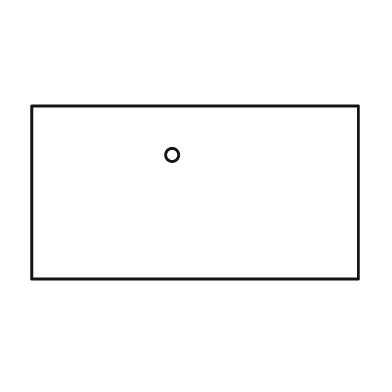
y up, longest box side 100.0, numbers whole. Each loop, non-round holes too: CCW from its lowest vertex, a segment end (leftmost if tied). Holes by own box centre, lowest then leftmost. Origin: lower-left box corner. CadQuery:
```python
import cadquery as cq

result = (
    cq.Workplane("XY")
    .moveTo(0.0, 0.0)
    .lineTo(100.0, 0.0)
    .lineTo(100.0, 53.0)
    .lineTo(0.0, 53.0)
    .close()
    .moveTo(43.0, 38.0)
    .circle(2.0)
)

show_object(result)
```